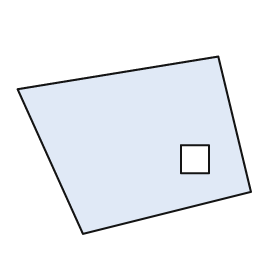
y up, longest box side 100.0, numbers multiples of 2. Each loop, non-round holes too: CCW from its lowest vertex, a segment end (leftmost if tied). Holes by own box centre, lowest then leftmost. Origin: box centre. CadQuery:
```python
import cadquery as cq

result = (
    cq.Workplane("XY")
    .moveTo(-22.0, -38.0)
    .lineTo(50.0, -20.0)
    .lineTo(36.0, 38.0)
    .lineTo(-50.0, 24.0)
    .close()
    .moveTo(20.0, -12.0)
    .lineTo(32.0, -12.0)
    .lineTo(32.0, 0.0)
    .lineTo(20.0, 0.0)
    .close()
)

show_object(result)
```